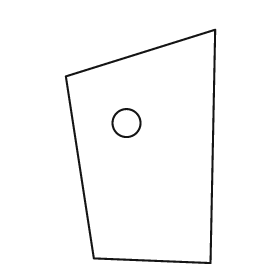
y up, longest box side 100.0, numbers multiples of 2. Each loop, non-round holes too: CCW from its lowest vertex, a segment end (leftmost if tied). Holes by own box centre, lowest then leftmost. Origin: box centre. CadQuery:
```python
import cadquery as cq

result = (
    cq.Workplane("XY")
    .moveTo(30.0, -50.0)
    .lineTo(32.0, 50.0)
    .lineTo(-32.0, 30.0)
    .lineTo(-20.0, -48.0)
    .close()
    .moveTo(-6.0, 10.0)
    .circle(6.0)
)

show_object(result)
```